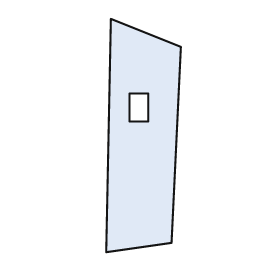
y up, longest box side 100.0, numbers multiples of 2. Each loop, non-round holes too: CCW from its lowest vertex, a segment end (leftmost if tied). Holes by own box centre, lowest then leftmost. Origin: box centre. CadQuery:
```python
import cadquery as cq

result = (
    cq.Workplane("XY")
    .moveTo(-16.0, -50.0)
    .lineTo(12.0, -46.0)
    .lineTo(16.0, 38.0)
    .lineTo(-14.0, 50.0)
    .close()
    .moveTo(-6.0, 6.0)
    .lineTo(2.0, 6.0)
    .lineTo(2.0, 18.0)
    .lineTo(-6.0, 18.0)
    .close()
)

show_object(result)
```